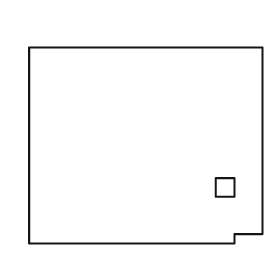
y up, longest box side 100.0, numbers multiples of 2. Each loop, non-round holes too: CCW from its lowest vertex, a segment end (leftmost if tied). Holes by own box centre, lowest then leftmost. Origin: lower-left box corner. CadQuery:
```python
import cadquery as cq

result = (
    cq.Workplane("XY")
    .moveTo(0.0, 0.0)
    .lineTo(88.0, 0.0)
    .lineTo(88.0, 4.0)
    .lineTo(100.0, 4.0)
    .lineTo(100.0, 84.0)
    .lineTo(0.0, 84.0)
    .close()
    .moveTo(80.0, 20.0)
    .lineTo(88.0, 20.0)
    .lineTo(88.0, 28.0)
    .lineTo(80.0, 28.0)
    .close()
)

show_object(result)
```